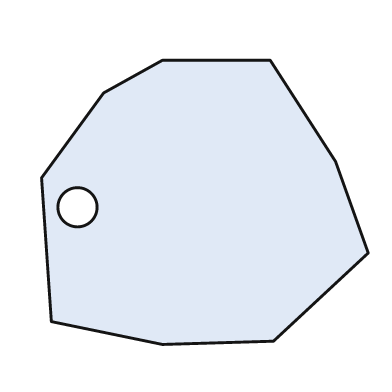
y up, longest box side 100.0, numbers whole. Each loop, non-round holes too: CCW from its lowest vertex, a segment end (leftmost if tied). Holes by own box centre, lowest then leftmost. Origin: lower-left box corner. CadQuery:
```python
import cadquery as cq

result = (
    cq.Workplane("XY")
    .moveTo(37.0, 0.0)
    .lineTo(71.0, 1.0)
    .lineTo(100.0, 28.0)
    .lineTo(90.0, 56.0)
    .lineTo(70.0, 87.0)
    .lineTo(37.0, 87.0)
    .lineTo(19.0, 77.0)
    .lineTo(0.0, 51.0)
    .lineTo(3.0, 7.0)
    .close()
    .moveTo(11.0, 42.0)
    .circle(6.0)
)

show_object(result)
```